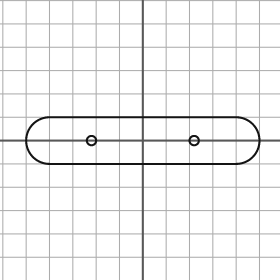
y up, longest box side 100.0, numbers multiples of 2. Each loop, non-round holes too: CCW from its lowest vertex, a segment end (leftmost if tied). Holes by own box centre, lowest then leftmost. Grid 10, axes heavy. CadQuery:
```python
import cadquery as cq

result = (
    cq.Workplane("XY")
    .moveTo(-40.0, -10.0)
    .lineTo(40.0, -10.0)
    .threePointArc((50.0, 0.0), (40.0, 10.0))
    .lineTo(-40.0, 10.0)
    .threePointArc((-50.0, 0.0), (-40.0, -10.0))
    .close()
    .moveTo(-22.0, 0.0)
    .circle(2.0)
    .moveTo(22.0, 0.0)
    .circle(2.0)
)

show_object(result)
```